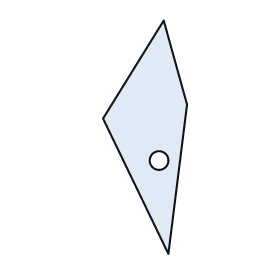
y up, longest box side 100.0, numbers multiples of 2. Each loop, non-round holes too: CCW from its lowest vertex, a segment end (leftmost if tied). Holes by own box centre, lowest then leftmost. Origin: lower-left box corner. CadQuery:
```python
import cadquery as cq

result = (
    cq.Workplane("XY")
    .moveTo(28.0, 0.0)
    .lineTo(36.0, 64.0)
    .lineTo(26.0, 100.0)
    .lineTo(0.0, 58.0)
    .close()
    .moveTo(24.0, 40.0)
    .circle(4.0)
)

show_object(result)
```